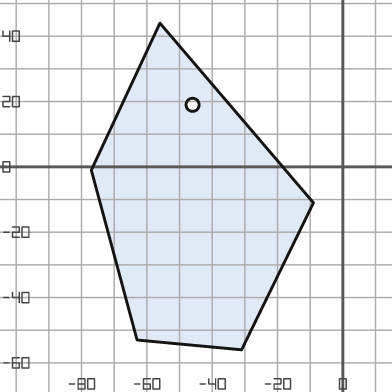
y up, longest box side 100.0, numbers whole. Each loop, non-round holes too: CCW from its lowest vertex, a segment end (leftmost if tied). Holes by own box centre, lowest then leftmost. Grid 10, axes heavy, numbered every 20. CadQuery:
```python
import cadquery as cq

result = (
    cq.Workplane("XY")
    .moveTo(-31.0, -56.0)
    .lineTo(-9.0, -11.0)
    .lineTo(-56.0, 44.0)
    .lineTo(-77.0, -1.0)
    .lineTo(-63.0, -53.0)
    .close()
    .moveTo(-46.0, 19.0)
    .circle(2.0)
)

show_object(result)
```